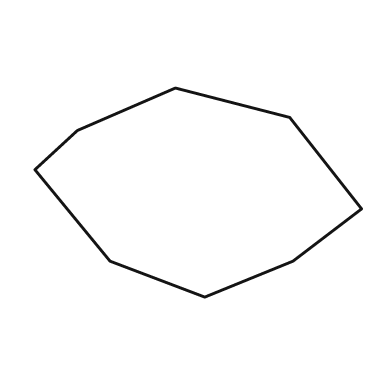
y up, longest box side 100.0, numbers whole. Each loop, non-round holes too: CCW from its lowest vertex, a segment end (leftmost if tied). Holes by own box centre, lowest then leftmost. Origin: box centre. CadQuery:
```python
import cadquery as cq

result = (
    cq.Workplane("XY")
    .moveTo(2.0, -32.0)
    .lineTo(29.0, -21.0)
    .lineTo(50.0, -5.0)
    .lineTo(28.0, 23.0)
    .lineTo(-7.0, 32.0)
    .lineTo(-37.0, 19.0)
    .lineTo(-50.0, 7.0)
    .lineTo(-27.0, -21.0)
    .close()
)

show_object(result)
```